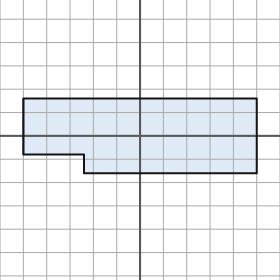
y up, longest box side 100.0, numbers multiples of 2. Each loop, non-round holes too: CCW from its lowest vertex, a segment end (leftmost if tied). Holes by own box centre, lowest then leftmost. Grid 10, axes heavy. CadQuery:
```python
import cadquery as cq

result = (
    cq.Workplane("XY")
    .moveTo(-24.0, -16.0)
    .lineTo(50.0, -16.0)
    .lineTo(50.0, 16.0)
    .lineTo(-50.0, 16.0)
    .lineTo(-50.0, -8.0)
    .lineTo(-24.0, -8.0)
    .close()
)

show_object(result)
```